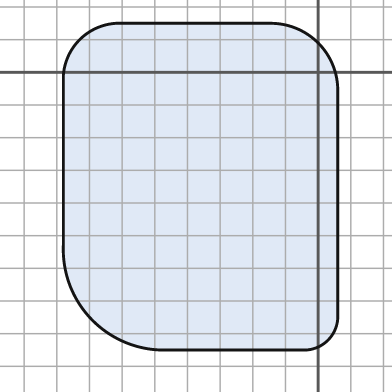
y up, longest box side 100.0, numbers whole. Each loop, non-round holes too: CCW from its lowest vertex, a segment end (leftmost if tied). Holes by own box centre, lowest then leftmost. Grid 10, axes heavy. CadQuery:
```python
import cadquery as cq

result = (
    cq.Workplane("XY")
    .moveTo(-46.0, -85.0)
    .lineTo(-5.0, -85.0)
    .threePointArc((3.0, -82.0), (6.0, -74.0))
    .lineTo(6.0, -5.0)
    .threePointArc((0.0, 9.0), (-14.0, 15.0))
    .lineTo(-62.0, 15.0)
    .threePointArc((-73.0, 10.0), (-78.0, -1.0))
    .lineTo(-78.0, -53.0)
    .threePointArc((-69.0, -76.0), (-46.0, -85.0))
    .close()
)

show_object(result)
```